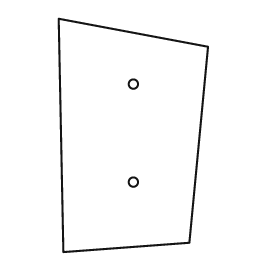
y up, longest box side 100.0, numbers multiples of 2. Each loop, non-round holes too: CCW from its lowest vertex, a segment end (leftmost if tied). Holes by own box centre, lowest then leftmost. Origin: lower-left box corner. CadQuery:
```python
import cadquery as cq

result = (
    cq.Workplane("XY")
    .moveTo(2.0, 0.0)
    .lineTo(56.0, 4.0)
    .lineTo(64.0, 88.0)
    .lineTo(0.0, 100.0)
    .close()
    .moveTo(32.0, 30.0)
    .circle(2.0)
    .moveTo(32.0, 72.0)
    .circle(2.0)
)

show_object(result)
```